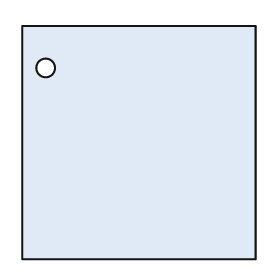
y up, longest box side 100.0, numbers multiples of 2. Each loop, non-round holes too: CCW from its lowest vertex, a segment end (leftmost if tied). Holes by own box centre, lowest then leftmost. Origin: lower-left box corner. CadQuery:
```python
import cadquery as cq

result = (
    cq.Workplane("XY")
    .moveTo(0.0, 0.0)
    .lineTo(100.0, 0.0)
    .lineTo(100.0, 100.0)
    .lineTo(0.0, 100.0)
    .close()
    .moveTo(10.0, 82.0)
    .circle(4.0)
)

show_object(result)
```